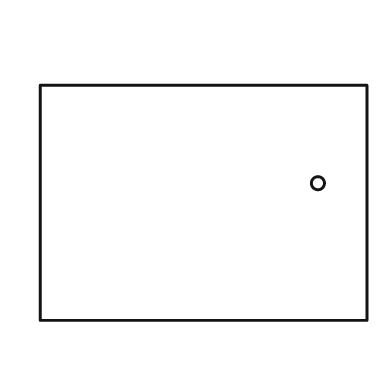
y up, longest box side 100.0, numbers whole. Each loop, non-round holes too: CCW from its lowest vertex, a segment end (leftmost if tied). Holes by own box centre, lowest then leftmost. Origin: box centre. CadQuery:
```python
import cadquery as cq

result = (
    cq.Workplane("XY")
    .moveTo(-50.0, -36.0)
    .lineTo(50.0, -36.0)
    .lineTo(50.0, 36.0)
    .lineTo(-50.0, 36.0)
    .close()
    .moveTo(35.0, 6.0)
    .circle(2.0)
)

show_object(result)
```